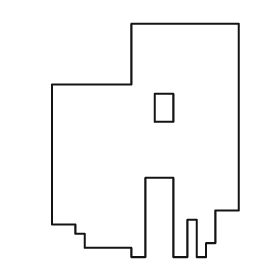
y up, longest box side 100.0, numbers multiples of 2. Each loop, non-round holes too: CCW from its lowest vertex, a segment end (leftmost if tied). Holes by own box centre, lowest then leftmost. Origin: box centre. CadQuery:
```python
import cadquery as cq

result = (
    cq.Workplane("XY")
    .moveTo(-6.0, -50.0)
    .lineTo(0.0, -50.0)
    .lineTo(0.0, -16.0)
    .lineTo(12.0, -16.0)
    .lineTo(12.0, -50.0)
    .lineTo(18.0, -50.0)
    .lineTo(18.0, -34.0)
    .lineTo(22.0, -34.0)
    .lineTo(22.0, -50.0)
    .lineTo(26.0, -50.0)
    .lineTo(26.0, -44.0)
    .lineTo(30.0, -44.0)
    .lineTo(30.0, -30.0)
    .lineTo(40.0, -30.0)
    .lineTo(40.0, 50.0)
    .lineTo(-6.0, 50.0)
    .lineTo(-6.0, 24.0)
    .lineTo(-40.0, 24.0)
    .lineTo(-40.0, -36.0)
    .lineTo(-30.0, -36.0)
    .lineTo(-30.0, -40.0)
    .lineTo(-26.0, -40.0)
    .lineTo(-26.0, -46.0)
    .lineTo(-6.0, -46.0)
    .close()
    .moveTo(4.0, 8.0)
    .lineTo(12.0, 8.0)
    .lineTo(12.0, 20.0)
    .lineTo(4.0, 20.0)
    .close()
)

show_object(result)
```